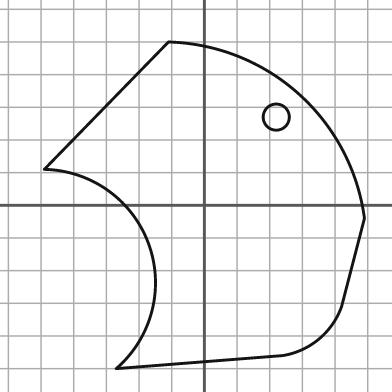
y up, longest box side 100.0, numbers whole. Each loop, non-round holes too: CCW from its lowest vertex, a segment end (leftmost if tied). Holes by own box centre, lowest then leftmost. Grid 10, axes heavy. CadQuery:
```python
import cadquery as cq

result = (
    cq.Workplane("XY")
    .moveTo(-27.0, -50.0)
    .lineTo(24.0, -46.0)
    .threePointArc((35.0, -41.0), (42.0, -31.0))
    .lineTo(49.0, -4.0)
    .threePointArc((29.0, 34.0), (-11.0, 50.0))
    .lineTo(-49.0, 11.0)
    .threePointArc((-17.0, -12.0), (-27.0, -50.0))
    .close()
    .moveTo(22.0, 27.0)
    .circle(4.0)
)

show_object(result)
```